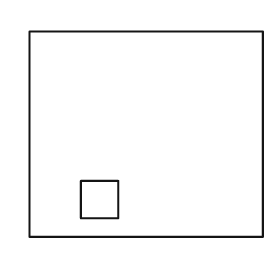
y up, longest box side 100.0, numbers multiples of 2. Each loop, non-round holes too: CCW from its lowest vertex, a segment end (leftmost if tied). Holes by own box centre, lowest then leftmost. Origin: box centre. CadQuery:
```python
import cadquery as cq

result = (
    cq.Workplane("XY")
    .moveTo(-50.0, -44.0)
    .lineTo(50.0, -44.0)
    .lineTo(50.0, 44.0)
    .lineTo(-50.0, 44.0)
    .close()
    .moveTo(-28.0, -36.0)
    .lineTo(-12.0, -36.0)
    .lineTo(-12.0, -20.0)
    .lineTo(-28.0, -20.0)
    .close()
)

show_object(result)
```